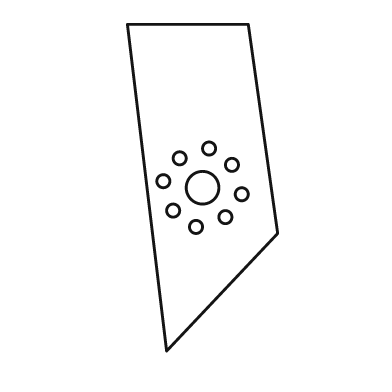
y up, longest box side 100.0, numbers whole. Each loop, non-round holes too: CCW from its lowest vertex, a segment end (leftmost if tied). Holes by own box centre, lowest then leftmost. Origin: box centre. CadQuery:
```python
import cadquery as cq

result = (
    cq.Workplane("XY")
    .moveTo(-11.0, -50.0)
    .lineTo(23.0, -14.0)
    .lineTo(14.0, 50.0)
    .lineTo(-23.0, 50.0)
    .close()
    .moveTo(-2.0, -12.0)
    .circle(2.0)
    .moveTo(7.0, -9.0)
    .circle(2.0)
    .moveTo(-9.0, -7.0)
    .circle(2.0)
    .moveTo(12.0, -2.0)
    .circle(2.0)
    .moveTo(0.0, 0.0)
    .circle(5.0)
    .moveTo(-12.0, 2.0)
    .circle(2.0)
    .moveTo(9.0, 7.0)
    .circle(2.0)
    .moveTo(-7.0, 9.0)
    .circle(2.0)
    .moveTo(2.0, 12.0)
    .circle(2.0)
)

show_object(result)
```